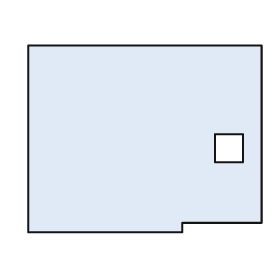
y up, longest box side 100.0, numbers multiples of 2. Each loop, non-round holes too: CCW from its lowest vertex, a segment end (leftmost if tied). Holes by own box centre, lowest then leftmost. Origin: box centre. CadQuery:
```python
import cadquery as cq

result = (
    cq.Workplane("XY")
    .moveTo(-50.0, -40.0)
    .lineTo(16.0, -40.0)
    .lineTo(16.0, -36.0)
    .lineTo(50.0, -36.0)
    .lineTo(50.0, 40.0)
    .lineTo(-50.0, 40.0)
    .close()
    .moveTo(30.0, -10.0)
    .lineTo(42.0, -10.0)
    .lineTo(42.0, 2.0)
    .lineTo(30.0, 2.0)
    .close()
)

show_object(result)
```